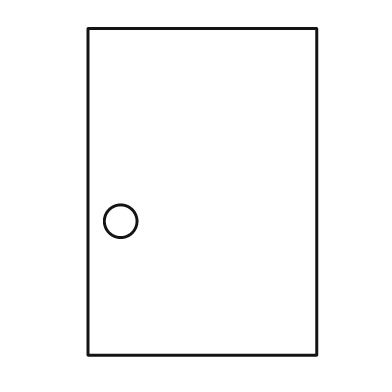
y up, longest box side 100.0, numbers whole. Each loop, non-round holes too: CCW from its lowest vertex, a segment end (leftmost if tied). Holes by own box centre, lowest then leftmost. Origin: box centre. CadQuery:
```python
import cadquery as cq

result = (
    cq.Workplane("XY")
    .moveTo(-35.0, -50.0)
    .lineTo(35.0, -50.0)
    .lineTo(35.0, 50.0)
    .lineTo(-35.0, 50.0)
    .close()
    .moveTo(-25.0, -9.0)
    .circle(5.0)
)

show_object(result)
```